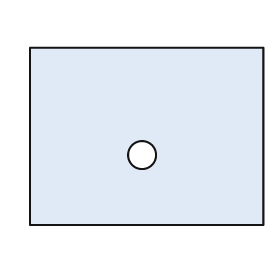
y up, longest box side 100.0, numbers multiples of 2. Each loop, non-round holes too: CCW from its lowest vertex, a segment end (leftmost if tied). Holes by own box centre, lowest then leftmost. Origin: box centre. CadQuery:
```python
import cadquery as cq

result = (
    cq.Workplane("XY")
    .moveTo(-50.0, -38.0)
    .lineTo(50.0, -38.0)
    .lineTo(50.0, 38.0)
    .lineTo(-50.0, 38.0)
    .close()
    .moveTo(-2.0, -8.0)
    .circle(6.0)
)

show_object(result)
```